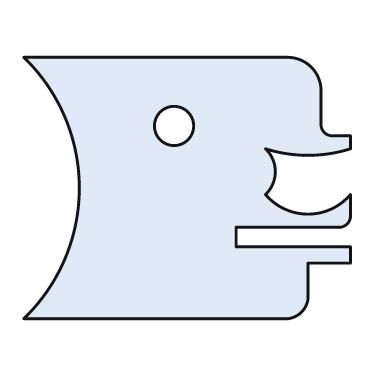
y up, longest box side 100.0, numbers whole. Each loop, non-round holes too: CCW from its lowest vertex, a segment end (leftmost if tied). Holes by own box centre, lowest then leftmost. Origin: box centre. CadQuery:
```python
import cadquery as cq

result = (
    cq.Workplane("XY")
    .moveTo(-50.0, -40.0)
    .lineTo(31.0, -40.0)
    .threePointArc((35.0, -38.0), (37.0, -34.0))
    .lineTo(37.0, -23.0)
    .lineTo(50.0, -23.0)
    .lineTo(50.0, -18.0)
    .lineTo(15.0, -18.0)
    .lineTo(15.0, -12.0)
    .lineTo(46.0, -12.0)
    .threePointArc((49.0, -11.0), (50.0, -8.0))
    .lineTo(50.0, -2.0)
    .threePointArc((37.0, -8.0), (24.0, -2.0))
    .threePointArc((27.0, 5.0), (24.0, 12.0))
    .threePointArc((37.0, 10.0), (50.0, 12.0))
    .lineTo(50.0, 16.0)
    .lineTo(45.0, 16.0)
    .threePointArc((42.0, 17.0), (41.0, 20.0))
    .lineTo(41.0, 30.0)
    .threePointArc((38.0, 37.0), (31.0, 40.0))
    .lineTo(-50.0, 40.0)
    .threePointArc((-33.0, 0.0), (-50.0, -40.0))
    .close()
    .moveTo(-4.0, 19.0)
    .circle(6.0)
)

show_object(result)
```